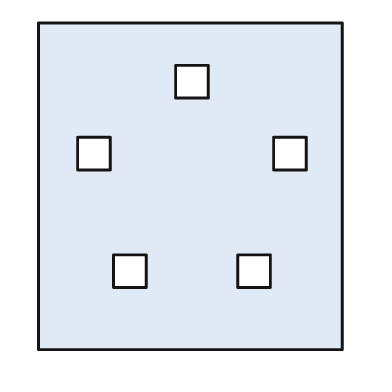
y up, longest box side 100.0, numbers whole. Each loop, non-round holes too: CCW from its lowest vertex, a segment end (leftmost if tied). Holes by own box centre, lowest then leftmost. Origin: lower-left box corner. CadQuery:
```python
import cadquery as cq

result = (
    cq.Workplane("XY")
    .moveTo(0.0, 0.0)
    .lineTo(93.0, 0.0)
    .lineTo(93.0, 100.0)
    .lineTo(0.0, 100.0)
    .close()
    .moveTo(23.0, 19.0)
    .lineTo(33.0, 19.0)
    .lineTo(33.0, 29.0)
    .lineTo(23.0, 29.0)
    .close()
    .moveTo(61.0, 19.0)
    .lineTo(71.0, 19.0)
    .lineTo(71.0, 29.0)
    .lineTo(61.0, 29.0)
    .close()
    .moveTo(12.0, 55.0)
    .lineTo(22.0, 55.0)
    .lineTo(22.0, 65.0)
    .lineTo(12.0, 65.0)
    .close()
    .moveTo(72.0, 55.0)
    .lineTo(82.0, 55.0)
    .lineTo(82.0, 65.0)
    .lineTo(72.0, 65.0)
    .close()
    .moveTo(42.0, 77.0)
    .lineTo(52.0, 77.0)
    .lineTo(52.0, 87.0)
    .lineTo(42.0, 87.0)
    .close()
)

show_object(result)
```